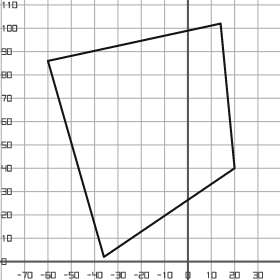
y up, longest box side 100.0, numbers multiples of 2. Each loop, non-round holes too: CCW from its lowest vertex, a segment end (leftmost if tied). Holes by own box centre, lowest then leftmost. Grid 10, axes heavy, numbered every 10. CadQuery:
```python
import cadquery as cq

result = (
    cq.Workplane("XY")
    .moveTo(-36.0, 2.0)
    .lineTo(20.0, 40.0)
    .lineTo(14.0, 102.0)
    .lineTo(-60.0, 86.0)
    .close()
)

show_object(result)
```